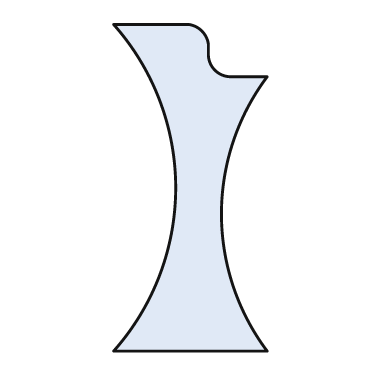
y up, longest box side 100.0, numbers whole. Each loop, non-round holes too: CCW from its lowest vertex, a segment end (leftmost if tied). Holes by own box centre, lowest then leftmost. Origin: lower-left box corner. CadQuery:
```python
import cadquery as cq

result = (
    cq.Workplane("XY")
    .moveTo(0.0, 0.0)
    .lineTo(47.0, 0.0)
    .threePointArc((33.0, 42.0), (47.0, 84.0))
    .lineTo(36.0, 84.0)
    .threePointArc((31.0, 86.0), (29.0, 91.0))
    .lineTo(29.0, 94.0)
    .threePointArc((27.0, 98.0), (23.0, 100.0))
    .lineTo(0.0, 100.0)
    .threePointArc((19.0, 50.0), (0.0, 0.0))
    .close()
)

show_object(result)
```